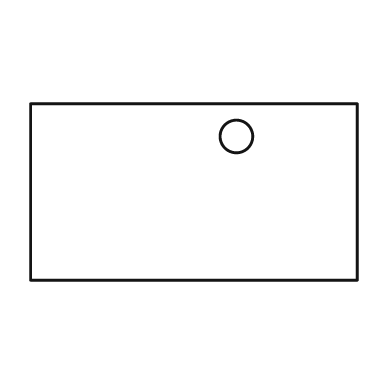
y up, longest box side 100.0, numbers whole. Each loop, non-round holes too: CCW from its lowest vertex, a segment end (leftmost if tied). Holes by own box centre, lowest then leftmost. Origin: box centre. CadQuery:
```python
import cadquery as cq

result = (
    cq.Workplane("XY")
    .moveTo(-50.0, -27.0)
    .lineTo(50.0, -27.0)
    .lineTo(50.0, 27.0)
    .lineTo(-50.0, 27.0)
    .close()
    .moveTo(13.0, 17.0)
    .circle(5.0)
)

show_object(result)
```